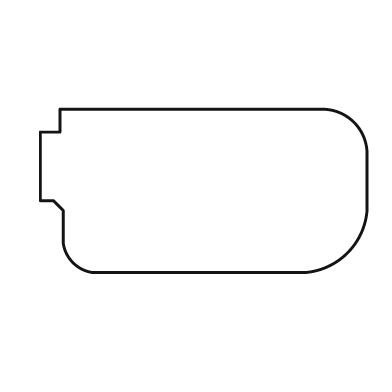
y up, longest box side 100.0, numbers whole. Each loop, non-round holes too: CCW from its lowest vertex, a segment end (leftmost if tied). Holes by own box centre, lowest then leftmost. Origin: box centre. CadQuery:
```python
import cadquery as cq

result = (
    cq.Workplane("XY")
    .moveTo(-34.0, -25.0)
    .lineTo(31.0, -25.0)
    .threePointArc((44.0, -19.0), (50.0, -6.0))
    .lineTo(50.0, 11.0)
    .threePointArc((46.0, 21.0), (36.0, 25.0))
    .lineTo(-44.0, 25.0)
    .lineTo(-44.0, 18.0)
    .lineTo(-50.0, 18.0)
    .lineTo(-50.0, -3.0)
    .lineTo(-46.0, -3.0)
    .lineTo(-43.0, -6.0)
    .lineTo(-43.0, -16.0)
    .threePointArc((-40.0, -22.0), (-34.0, -25.0))
    .close()
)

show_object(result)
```